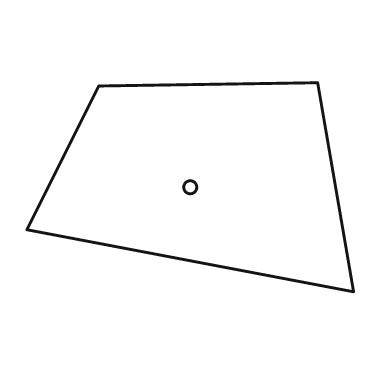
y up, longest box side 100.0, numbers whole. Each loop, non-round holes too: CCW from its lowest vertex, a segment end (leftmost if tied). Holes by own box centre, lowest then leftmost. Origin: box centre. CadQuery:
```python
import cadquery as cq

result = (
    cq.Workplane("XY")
    .moveTo(50.0, -32.0)
    .lineTo(39.0, 32.0)
    .lineTo(-28.0, 31.0)
    .lineTo(-50.0, -13.0)
    .close()
    .moveTo(0.0, 0.0)
    .circle(2.0)
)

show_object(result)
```